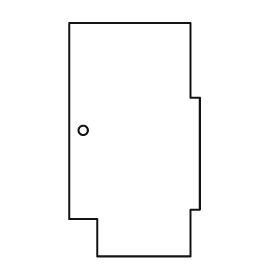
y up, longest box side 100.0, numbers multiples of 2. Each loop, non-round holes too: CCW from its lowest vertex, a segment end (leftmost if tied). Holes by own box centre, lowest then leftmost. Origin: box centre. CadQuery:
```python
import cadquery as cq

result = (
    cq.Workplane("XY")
    .moveTo(-16.0, -50.0)
    .lineTo(24.0, -50.0)
    .lineTo(24.0, -30.0)
    .lineTo(28.0, -30.0)
    .lineTo(28.0, 18.0)
    .lineTo(24.0, 18.0)
    .lineTo(24.0, 50.0)
    .lineTo(-28.0, 50.0)
    .lineTo(-28.0, -34.0)
    .lineTo(-16.0, -34.0)
    .close()
    .moveTo(-22.0, 4.0)
    .circle(2.0)
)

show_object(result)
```